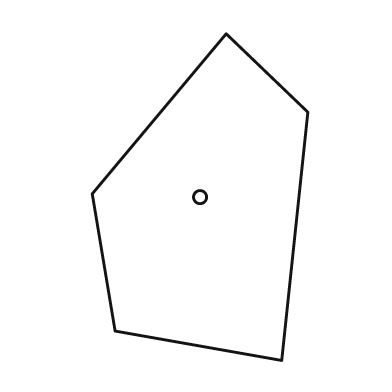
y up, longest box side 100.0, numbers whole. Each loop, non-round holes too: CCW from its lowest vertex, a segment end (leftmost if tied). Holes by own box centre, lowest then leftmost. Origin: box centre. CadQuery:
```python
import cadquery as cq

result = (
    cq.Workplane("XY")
    .moveTo(25.0, -50.0)
    .lineTo(33.0, 26.0)
    .lineTo(8.0, 50.0)
    .lineTo(-33.0, 1.0)
    .lineTo(-26.0, -41.0)
    .close()
    .moveTo(0.0, 0.0)
    .circle(2.0)
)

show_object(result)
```